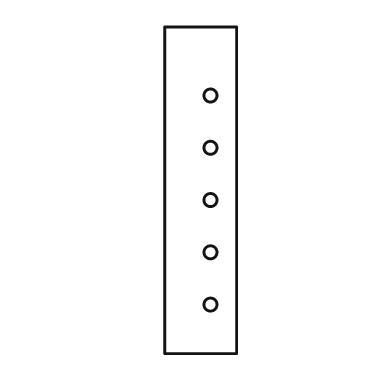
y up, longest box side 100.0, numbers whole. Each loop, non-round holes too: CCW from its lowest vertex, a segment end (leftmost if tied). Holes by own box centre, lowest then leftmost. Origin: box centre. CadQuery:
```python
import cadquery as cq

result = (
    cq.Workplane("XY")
    .moveTo(-11.0, -50.0)
    .lineTo(11.0, -50.0)
    .lineTo(11.0, 50.0)
    .lineTo(-11.0, 50.0)
    .close()
    .moveTo(3.0, -35.0)
    .circle(2.0)
    .moveTo(3.0, -19.0)
    .circle(2.0)
    .moveTo(3.0, -3.0)
    .circle(2.0)
    .moveTo(3.0, 13.0)
    .circle(2.0)
    .moveTo(3.0, 29.0)
    .circle(2.0)
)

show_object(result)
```